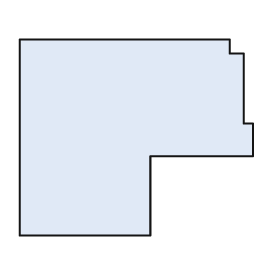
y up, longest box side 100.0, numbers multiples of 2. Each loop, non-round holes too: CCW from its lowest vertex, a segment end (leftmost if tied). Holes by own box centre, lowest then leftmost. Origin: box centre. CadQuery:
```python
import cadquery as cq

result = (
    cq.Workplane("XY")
    .moveTo(-50.0, -42.0)
    .lineTo(6.0, -42.0)
    .lineTo(6.0, -8.0)
    .lineTo(50.0, -8.0)
    .lineTo(50.0, 6.0)
    .lineTo(46.0, 6.0)
    .lineTo(46.0, 36.0)
    .lineTo(40.0, 36.0)
    .lineTo(40.0, 42.0)
    .lineTo(-50.0, 42.0)
    .close()
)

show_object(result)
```